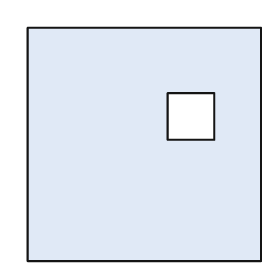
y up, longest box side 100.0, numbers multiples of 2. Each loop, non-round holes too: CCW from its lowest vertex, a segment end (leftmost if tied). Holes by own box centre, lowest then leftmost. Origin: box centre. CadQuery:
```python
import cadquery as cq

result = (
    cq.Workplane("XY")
    .moveTo(-50.0, -50.0)
    .lineTo(50.0, -50.0)
    .lineTo(50.0, 50.0)
    .lineTo(-50.0, 50.0)
    .close()
    .moveTo(10.0, 2.0)
    .lineTo(30.0, 2.0)
    .lineTo(30.0, 22.0)
    .lineTo(10.0, 22.0)
    .close()
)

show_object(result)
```